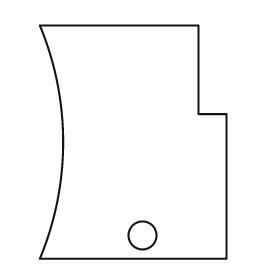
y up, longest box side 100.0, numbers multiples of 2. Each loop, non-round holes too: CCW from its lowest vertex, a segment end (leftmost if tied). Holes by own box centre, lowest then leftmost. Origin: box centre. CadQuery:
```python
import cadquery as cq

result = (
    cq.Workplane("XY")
    .moveTo(-40.0, -50.0)
    .lineTo(40.0, -50.0)
    .lineTo(40.0, 12.0)
    .lineTo(28.0, 12.0)
    .lineTo(28.0, 50.0)
    .lineTo(-40.0, 50.0)
    .threePointArc((-30.0, 0.0), (-40.0, -50.0))
    .close()
    .moveTo(4.0, -40.0)
    .circle(6.0)
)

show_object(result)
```